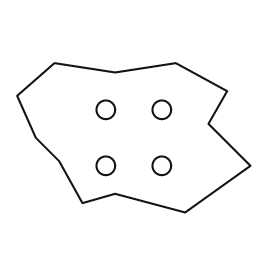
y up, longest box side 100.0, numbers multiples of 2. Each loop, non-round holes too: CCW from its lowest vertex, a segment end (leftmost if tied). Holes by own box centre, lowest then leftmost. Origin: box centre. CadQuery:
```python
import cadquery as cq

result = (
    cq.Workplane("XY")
    .moveTo(22.0, -32.0)
    .lineTo(50.0, -12.0)
    .lineTo(32.0, 6.0)
    .lineTo(40.0, 20.0)
    .lineTo(18.0, 32.0)
    .lineTo(-8.0, 28.0)
    .lineTo(-34.0, 32.0)
    .lineTo(-50.0, 18.0)
    .lineTo(-42.0, 0.0)
    .lineTo(-32.0, -10.0)
    .lineTo(-22.0, -28.0)
    .lineTo(-8.0, -24.0)
    .close()
    .moveTo(-12.0, -12.0)
    .circle(4.0)
    .moveTo(12.0, -12.0)
    .circle(4.0)
    .moveTo(-12.0, 12.0)
    .circle(4.0)
    .moveTo(12.0, 12.0)
    .circle(4.0)
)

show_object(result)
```